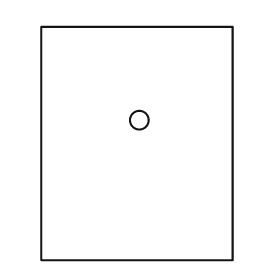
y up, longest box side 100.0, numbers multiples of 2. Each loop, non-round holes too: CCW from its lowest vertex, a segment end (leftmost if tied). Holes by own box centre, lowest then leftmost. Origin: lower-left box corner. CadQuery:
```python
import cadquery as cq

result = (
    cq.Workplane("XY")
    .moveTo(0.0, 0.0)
    .lineTo(82.0, 0.0)
    .lineTo(82.0, 100.0)
    .lineTo(0.0, 100.0)
    .close()
    .moveTo(42.0, 60.0)
    .circle(4.0)
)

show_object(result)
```